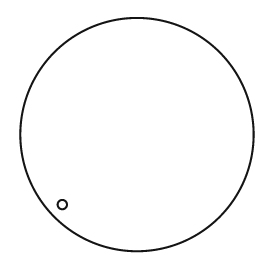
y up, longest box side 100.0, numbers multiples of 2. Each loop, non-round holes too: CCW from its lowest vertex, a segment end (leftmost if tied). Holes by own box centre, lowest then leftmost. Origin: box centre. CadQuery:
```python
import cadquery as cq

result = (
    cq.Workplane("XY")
    .moveTo(0.0, 0.0)
    .circle(50.0)
    .moveTo(-32.0, -30.0)
    .circle(2.0)
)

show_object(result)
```